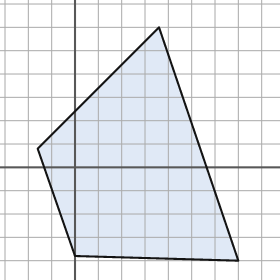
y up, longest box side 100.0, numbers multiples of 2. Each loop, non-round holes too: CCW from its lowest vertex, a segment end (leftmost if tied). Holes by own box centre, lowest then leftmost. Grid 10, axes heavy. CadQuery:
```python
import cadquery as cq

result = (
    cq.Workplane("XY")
    .moveTo(70.0, -40.0)
    .lineTo(36.0, 60.0)
    .lineTo(-16.0, 8.0)
    .lineTo(0.0, -38.0)
    .close()
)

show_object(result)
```